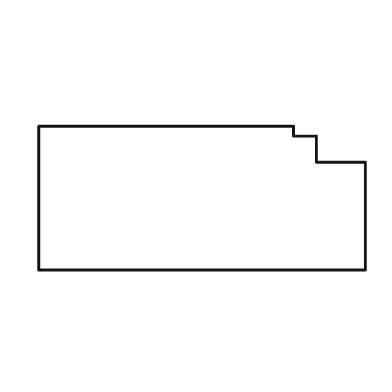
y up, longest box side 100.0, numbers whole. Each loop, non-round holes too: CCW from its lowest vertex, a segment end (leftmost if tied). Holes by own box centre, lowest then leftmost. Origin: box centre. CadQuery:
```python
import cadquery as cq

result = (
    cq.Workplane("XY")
    .moveTo(-50.0, -22.0)
    .lineTo(50.0, -22.0)
    .lineTo(50.0, 11.0)
    .lineTo(35.0, 11.0)
    .lineTo(35.0, 19.0)
    .lineTo(28.0, 19.0)
    .lineTo(28.0, 22.0)
    .lineTo(-50.0, 22.0)
    .close()
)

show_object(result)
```